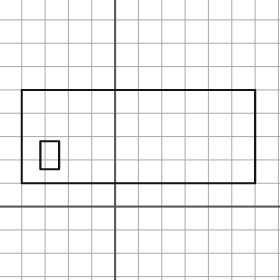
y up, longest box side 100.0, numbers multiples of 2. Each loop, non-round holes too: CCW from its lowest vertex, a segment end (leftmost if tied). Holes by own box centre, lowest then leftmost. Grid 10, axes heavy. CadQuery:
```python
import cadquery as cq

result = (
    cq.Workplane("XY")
    .moveTo(-40.0, 10.0)
    .lineTo(60.0, 10.0)
    .lineTo(60.0, 50.0)
    .lineTo(-40.0, 50.0)
    .close()
    .moveTo(-32.0, 16.0)
    .lineTo(-24.0, 16.0)
    .lineTo(-24.0, 28.0)
    .lineTo(-32.0, 28.0)
    .close()
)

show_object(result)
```